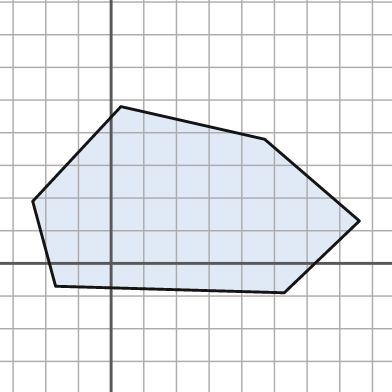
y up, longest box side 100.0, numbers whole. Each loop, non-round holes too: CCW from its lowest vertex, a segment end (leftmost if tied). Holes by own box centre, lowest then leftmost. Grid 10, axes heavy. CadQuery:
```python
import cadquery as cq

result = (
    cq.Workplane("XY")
    .moveTo(53.0, -9.0)
    .lineTo(76.0, 13.0)
    .lineTo(47.0, 38.0)
    .lineTo(3.0, 48.0)
    .lineTo(-24.0, 19.0)
    .lineTo(-17.0, -7.0)
    .close()
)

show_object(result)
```